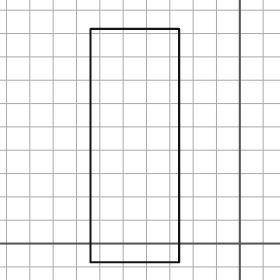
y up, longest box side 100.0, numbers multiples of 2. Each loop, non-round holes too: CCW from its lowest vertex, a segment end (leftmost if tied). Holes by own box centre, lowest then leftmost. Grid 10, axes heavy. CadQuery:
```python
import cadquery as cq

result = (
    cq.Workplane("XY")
    .moveTo(-64.0, -8.0)
    .lineTo(-26.0, -8.0)
    .lineTo(-26.0, 92.0)
    .lineTo(-64.0, 92.0)
    .close()
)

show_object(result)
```